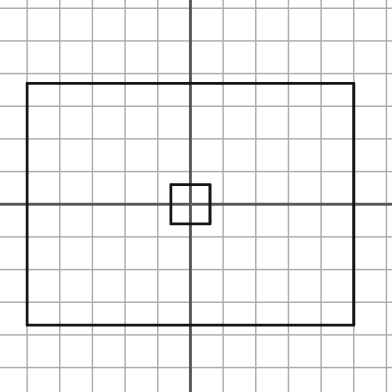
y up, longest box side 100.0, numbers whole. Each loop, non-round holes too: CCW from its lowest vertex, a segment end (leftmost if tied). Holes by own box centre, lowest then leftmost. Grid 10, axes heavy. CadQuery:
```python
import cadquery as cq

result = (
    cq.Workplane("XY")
    .moveTo(-50.0, -37.0)
    .lineTo(50.0, -37.0)
    .lineTo(50.0, 37.0)
    .lineTo(-50.0, 37.0)
    .close()
    .moveTo(-6.0, -6.0)
    .lineTo(6.0, -6.0)
    .lineTo(6.0, 6.0)
    .lineTo(-6.0, 6.0)
    .close()
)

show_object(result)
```